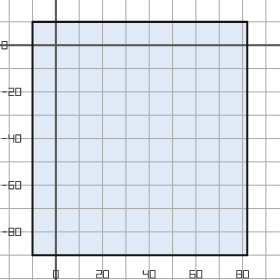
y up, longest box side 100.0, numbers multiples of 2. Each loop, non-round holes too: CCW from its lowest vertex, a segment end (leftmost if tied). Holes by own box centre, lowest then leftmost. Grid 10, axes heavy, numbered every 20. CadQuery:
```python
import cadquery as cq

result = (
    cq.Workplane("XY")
    .moveTo(-10.0, -90.0)
    .lineTo(82.0, -90.0)
    .lineTo(82.0, 10.0)
    .lineTo(-10.0, 10.0)
    .close()
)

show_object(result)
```